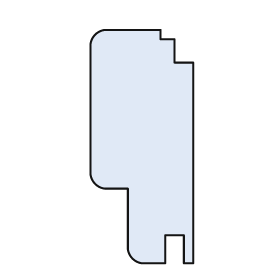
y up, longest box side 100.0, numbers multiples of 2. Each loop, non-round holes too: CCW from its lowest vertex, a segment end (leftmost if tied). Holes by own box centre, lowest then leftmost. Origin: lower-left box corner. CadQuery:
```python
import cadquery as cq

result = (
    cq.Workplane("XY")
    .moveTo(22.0, 0.0)
    .lineTo(32.0, 0.0)
    .lineTo(32.0, 12.0)
    .lineTo(40.0, 12.0)
    .lineTo(40.0, 0.0)
    .lineTo(44.0, 0.0)
    .lineTo(44.0, 86.0)
    .lineTo(36.0, 86.0)
    .lineTo(36.0, 96.0)
    .lineTo(30.0, 96.0)
    .lineTo(30.0, 100.0)
    .lineTo(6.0, 100.0)
    .threePointArc((2.0, 98.0), (0.0, 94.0))
    .lineTo(0.0, 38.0)
    .threePointArc((2.0, 34.0), (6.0, 32.0))
    .lineTo(16.0, 32.0)
    .lineTo(16.0, 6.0)
    .threePointArc((18.0, 2.0), (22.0, 0.0))
    .close()
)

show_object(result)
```